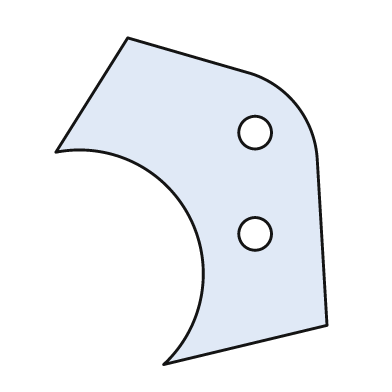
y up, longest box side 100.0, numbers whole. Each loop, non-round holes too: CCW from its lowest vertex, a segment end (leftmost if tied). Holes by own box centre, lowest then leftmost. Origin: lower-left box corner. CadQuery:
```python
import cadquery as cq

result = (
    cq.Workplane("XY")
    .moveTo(33.0, 0.0)
    .lineTo(83.0, 12.0)
    .lineTo(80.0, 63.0)
    .threePointArc((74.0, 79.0), (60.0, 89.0))
    .lineTo(22.0, 100.0)
    .lineTo(0.0, 65.0)
    .threePointArc((41.0, 45.0), (33.0, 0.0))
    .close()
    .moveTo(61.0, 40.0)
    .circle(5.0)
    .moveTo(61.0, 71.0)
    .circle(5.0)
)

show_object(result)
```